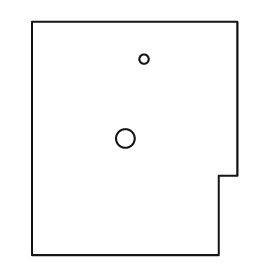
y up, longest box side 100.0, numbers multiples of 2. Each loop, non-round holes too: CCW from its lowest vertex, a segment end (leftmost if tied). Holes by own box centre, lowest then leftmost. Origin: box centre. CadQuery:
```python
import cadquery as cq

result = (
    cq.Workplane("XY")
    .moveTo(-44.0, -50.0)
    .lineTo(36.0, -50.0)
    .lineTo(36.0, -16.0)
    .lineTo(44.0, -16.0)
    .lineTo(44.0, 50.0)
    .lineTo(-44.0, 50.0)
    .close()
    .moveTo(-4.0, 0.0)
    .circle(4.0)
    .moveTo(4.0, 34.0)
    .circle(2.0)
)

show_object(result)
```